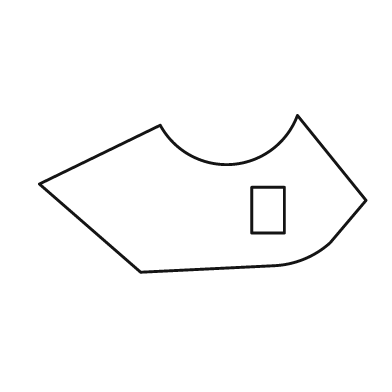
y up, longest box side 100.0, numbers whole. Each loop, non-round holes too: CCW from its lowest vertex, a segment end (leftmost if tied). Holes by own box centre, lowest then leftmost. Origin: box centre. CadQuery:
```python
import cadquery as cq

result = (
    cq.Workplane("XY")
    .moveTo(-19.0, -24.0)
    .lineTo(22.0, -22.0)
    .threePointArc((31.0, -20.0), (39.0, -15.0))
    .lineTo(50.0, -2.0)
    .lineTo(29.0, 24.0)
    .threePointArc((9.0, 9.0), (-13.0, 21.0))
    .lineTo(-50.0, 3.0)
    .close()
    .moveTo(15.0, -12.0)
    .lineTo(25.0, -12.0)
    .lineTo(25.0, 2.0)
    .lineTo(15.0, 2.0)
    .close()
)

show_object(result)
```